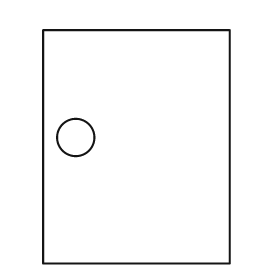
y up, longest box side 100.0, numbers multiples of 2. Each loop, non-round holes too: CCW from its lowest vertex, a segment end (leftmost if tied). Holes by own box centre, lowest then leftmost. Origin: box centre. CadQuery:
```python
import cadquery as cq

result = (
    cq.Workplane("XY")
    .moveTo(-40.0, -50.0)
    .lineTo(40.0, -50.0)
    .lineTo(40.0, 50.0)
    .lineTo(-40.0, 50.0)
    .close()
    .moveTo(-26.0, 4.0)
    .circle(8.0)
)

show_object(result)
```